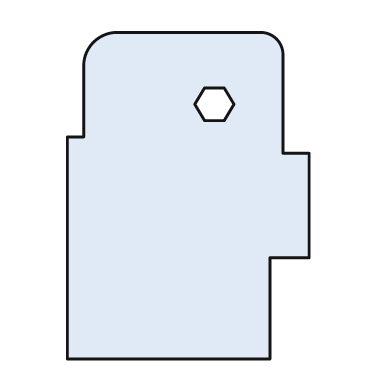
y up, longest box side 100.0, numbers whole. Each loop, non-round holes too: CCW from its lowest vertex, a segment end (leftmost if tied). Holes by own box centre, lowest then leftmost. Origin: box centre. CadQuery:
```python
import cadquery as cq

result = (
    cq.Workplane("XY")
    .moveTo(-37.0, -50.0)
    .lineTo(25.0, -50.0)
    .lineTo(25.0, -19.0)
    .lineTo(37.0, -19.0)
    .lineTo(37.0, 13.0)
    .lineTo(29.0, 13.0)
    .lineTo(29.0, 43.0)
    .threePointArc((27.0, 48.0), (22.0, 50.0))
    .lineTo(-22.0, 50.0)
    .threePointArc((-29.0, 47.0), (-32.0, 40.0))
    .lineTo(-32.0, 18.0)
    .lineTo(-37.0, 18.0)
    .close()
    .moveTo(5.0, 23.0)
    .lineTo(11.0, 23.0)
    .lineTo(14.0, 28.0)
    .lineTo(11.0, 33.0)
    .lineTo(5.0, 33.0)
    .lineTo(2.0, 28.0)
    .close()
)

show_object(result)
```